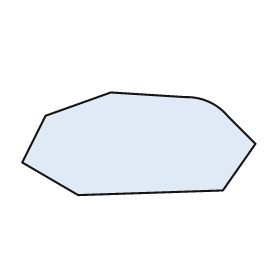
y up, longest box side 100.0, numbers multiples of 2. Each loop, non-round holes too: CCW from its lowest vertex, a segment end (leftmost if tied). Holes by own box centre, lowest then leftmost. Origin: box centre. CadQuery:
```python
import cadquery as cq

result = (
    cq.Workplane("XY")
    .moveTo(-26.0, -22.0)
    .lineTo(36.0, -20.0)
    .lineTo(50.0, 0.0)
    .lineTo(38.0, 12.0)
    .threePointArc((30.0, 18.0), (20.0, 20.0))
    .lineTo(-12.0, 22.0)
    .lineTo(-40.0, 12.0)
    .lineTo(-50.0, -8.0)
    .close()
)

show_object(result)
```